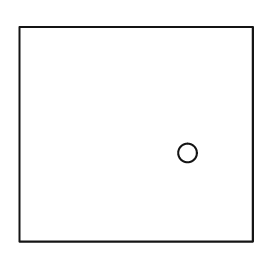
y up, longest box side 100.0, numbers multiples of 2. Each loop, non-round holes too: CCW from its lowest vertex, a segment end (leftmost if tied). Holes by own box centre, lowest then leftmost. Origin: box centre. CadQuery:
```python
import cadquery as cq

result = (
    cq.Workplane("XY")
    .moveTo(-50.0, -46.0)
    .lineTo(50.0, -46.0)
    .lineTo(50.0, 46.0)
    .lineTo(-50.0, 46.0)
    .close()
    .moveTo(22.0, -8.0)
    .circle(4.0)
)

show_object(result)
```